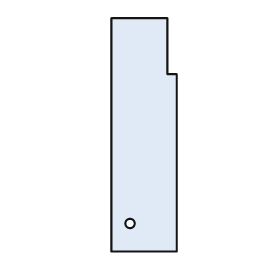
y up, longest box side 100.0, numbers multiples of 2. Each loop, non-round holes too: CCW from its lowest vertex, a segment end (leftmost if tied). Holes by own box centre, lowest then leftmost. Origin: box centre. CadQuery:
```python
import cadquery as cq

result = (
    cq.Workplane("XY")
    .moveTo(-14.0, -50.0)
    .lineTo(14.0, -50.0)
    .lineTo(14.0, 26.0)
    .lineTo(10.0, 26.0)
    .lineTo(10.0, 50.0)
    .lineTo(-14.0, 50.0)
    .close()
    .moveTo(-6.0, -38.0)
    .circle(2.0)
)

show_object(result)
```